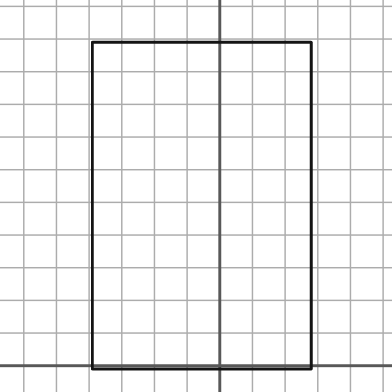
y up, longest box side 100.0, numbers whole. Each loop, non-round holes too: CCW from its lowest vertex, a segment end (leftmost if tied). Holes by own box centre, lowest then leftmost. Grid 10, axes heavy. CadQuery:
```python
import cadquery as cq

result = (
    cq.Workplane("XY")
    .moveTo(-39.0, -1.0)
    .lineTo(28.0, -1.0)
    .lineTo(28.0, 99.0)
    .lineTo(-39.0, 99.0)
    .close()
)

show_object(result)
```